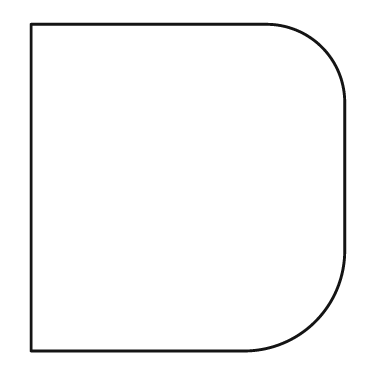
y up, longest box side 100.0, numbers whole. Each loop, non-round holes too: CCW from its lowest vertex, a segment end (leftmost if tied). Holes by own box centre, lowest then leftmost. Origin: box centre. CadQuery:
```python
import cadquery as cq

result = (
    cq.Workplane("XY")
    .moveTo(-48.0, -50.0)
    .lineTo(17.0, -50.0)
    .threePointArc((39.0, -41.0), (48.0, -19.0))
    .lineTo(48.0, 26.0)
    .threePointArc((41.0, 43.0), (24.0, 50.0))
    .lineTo(-48.0, 50.0)
    .close()
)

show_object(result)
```